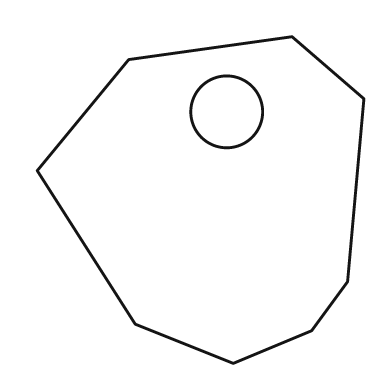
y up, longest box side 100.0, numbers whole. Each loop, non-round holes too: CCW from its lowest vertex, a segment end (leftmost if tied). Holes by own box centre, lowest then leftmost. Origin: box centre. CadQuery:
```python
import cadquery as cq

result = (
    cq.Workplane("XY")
    .moveTo(10.0, -50.0)
    .lineTo(34.0, -40.0)
    .lineTo(45.0, -25.0)
    .lineTo(50.0, 31.0)
    .lineTo(28.0, 50.0)
    .lineTo(-22.0, 43.0)
    .lineTo(-50.0, 9.0)
    .lineTo(-20.0, -38.0)
    .close()
    .moveTo(8.0, 27.0)
    .circle(11.0)
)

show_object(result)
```